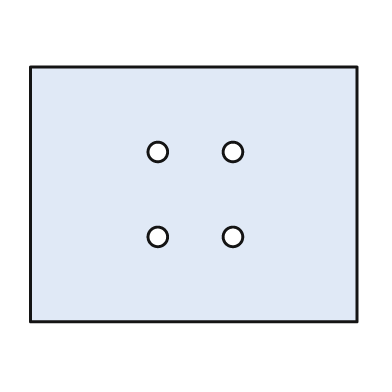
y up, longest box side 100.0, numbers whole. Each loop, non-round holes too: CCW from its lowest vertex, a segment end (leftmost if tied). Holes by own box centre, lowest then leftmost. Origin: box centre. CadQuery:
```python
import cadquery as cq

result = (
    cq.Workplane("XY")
    .moveTo(-50.0, -39.0)
    .lineTo(50.0, -39.0)
    .lineTo(50.0, 39.0)
    .lineTo(-50.0, 39.0)
    .close()
    .moveTo(-11.0, -13.0)
    .circle(3.0)
    .moveTo(12.0, -13.0)
    .circle(3.0)
    .moveTo(-11.0, 13.0)
    .circle(3.0)
    .moveTo(12.0, 13.0)
    .circle(3.0)
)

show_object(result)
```